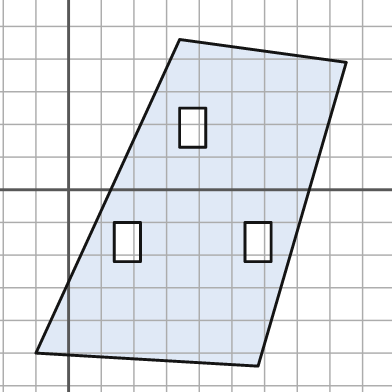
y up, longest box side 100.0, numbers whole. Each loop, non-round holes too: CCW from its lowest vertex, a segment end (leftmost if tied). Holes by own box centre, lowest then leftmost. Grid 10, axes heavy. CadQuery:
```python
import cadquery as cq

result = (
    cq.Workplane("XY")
    .moveTo(58.0, -54.0)
    .lineTo(85.0, 39.0)
    .lineTo(34.0, 46.0)
    .lineTo(-10.0, -50.0)
    .close()
    .moveTo(14.0, -22.0)
    .lineTo(22.0, -22.0)
    .lineTo(22.0, -10.0)
    .lineTo(14.0, -10.0)
    .close()
    .moveTo(54.0, -22.0)
    .lineTo(62.0, -22.0)
    .lineTo(62.0, -10.0)
    .lineTo(54.0, -10.0)
    .close()
    .moveTo(34.0, 13.0)
    .lineTo(42.0, 13.0)
    .lineTo(42.0, 25.0)
    .lineTo(34.0, 25.0)
    .close()
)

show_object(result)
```